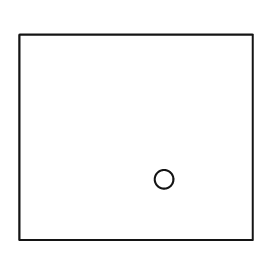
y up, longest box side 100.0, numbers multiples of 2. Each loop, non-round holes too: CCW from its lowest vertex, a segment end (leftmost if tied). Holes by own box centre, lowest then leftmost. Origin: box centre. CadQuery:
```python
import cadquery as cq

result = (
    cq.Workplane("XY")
    .moveTo(-50.0, -44.0)
    .lineTo(50.0, -44.0)
    .lineTo(50.0, 44.0)
    .lineTo(-50.0, 44.0)
    .close()
    .moveTo(12.0, -18.0)
    .circle(4.0)
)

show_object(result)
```